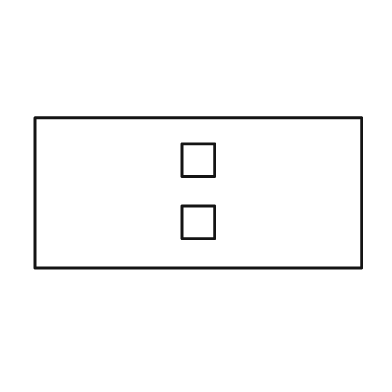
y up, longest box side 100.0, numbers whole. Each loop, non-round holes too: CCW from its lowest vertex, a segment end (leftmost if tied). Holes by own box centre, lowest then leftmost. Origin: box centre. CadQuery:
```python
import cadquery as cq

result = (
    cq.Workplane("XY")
    .moveTo(-50.0, -23.0)
    .lineTo(50.0, -23.0)
    .lineTo(50.0, 23.0)
    .lineTo(-50.0, 23.0)
    .close()
    .moveTo(-5.0, -14.0)
    .lineTo(5.0, -14.0)
    .lineTo(5.0, -4.0)
    .lineTo(-5.0, -4.0)
    .close()
    .moveTo(-5.0, 5.0)
    .lineTo(5.0, 5.0)
    .lineTo(5.0, 15.0)
    .lineTo(-5.0, 15.0)
    .close()
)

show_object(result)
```